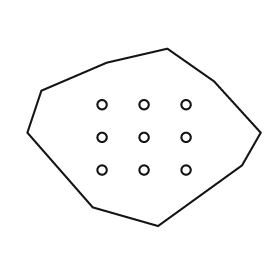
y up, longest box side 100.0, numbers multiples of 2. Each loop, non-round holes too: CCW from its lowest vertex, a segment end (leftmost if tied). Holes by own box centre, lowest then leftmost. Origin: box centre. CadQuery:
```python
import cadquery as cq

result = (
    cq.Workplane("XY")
    .moveTo(6.0, -38.0)
    .lineTo(42.0, -12.0)
    .lineTo(50.0, 2.0)
    .lineTo(30.0, 24.0)
    .lineTo(10.0, 38.0)
    .lineTo(-16.0, 32.0)
    .lineTo(-44.0, 20.0)
    .lineTo(-50.0, 2.0)
    .lineTo(-22.0, -30.0)
    .close()
    .moveTo(-18.0, -14.0)
    .circle(2.0)
    .moveTo(0.0, -14.0)
    .circle(2.0)
    .moveTo(18.0, -14.0)
    .circle(2.0)
    .moveTo(-18.0, 0.0)
    .circle(2.0)
    .moveTo(0.0, 0.0)
    .circle(2.0)
    .moveTo(18.0, 0.0)
    .circle(2.0)
    .moveTo(-18.0, 14.0)
    .circle(2.0)
    .moveTo(0.0, 14.0)
    .circle(2.0)
    .moveTo(18.0, 14.0)
    .circle(2.0)
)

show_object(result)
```